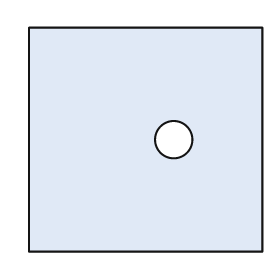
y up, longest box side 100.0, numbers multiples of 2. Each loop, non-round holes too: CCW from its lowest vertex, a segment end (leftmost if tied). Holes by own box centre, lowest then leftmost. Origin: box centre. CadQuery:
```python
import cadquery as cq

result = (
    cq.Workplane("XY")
    .moveTo(-50.0, -48.0)
    .lineTo(50.0, -48.0)
    .lineTo(50.0, 48.0)
    .lineTo(-50.0, 48.0)
    .close()
    .moveTo(12.0, 0.0)
    .circle(8.0)
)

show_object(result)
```